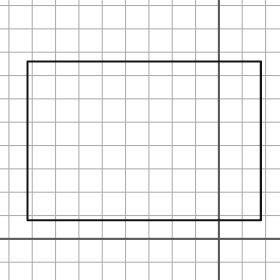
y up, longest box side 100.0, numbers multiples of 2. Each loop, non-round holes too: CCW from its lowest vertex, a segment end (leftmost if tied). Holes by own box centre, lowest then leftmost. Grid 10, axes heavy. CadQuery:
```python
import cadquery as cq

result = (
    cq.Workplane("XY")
    .moveTo(-82.0, 8.0)
    .lineTo(18.0, 8.0)
    .lineTo(18.0, 76.0)
    .lineTo(-82.0, 76.0)
    .close()
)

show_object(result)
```